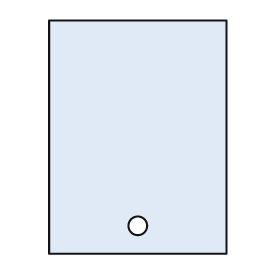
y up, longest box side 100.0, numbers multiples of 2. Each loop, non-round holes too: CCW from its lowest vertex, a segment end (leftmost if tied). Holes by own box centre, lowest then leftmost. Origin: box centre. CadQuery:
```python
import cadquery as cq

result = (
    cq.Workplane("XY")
    .moveTo(-38.0, -50.0)
    .lineTo(38.0, -50.0)
    .lineTo(38.0, 50.0)
    .lineTo(-38.0, 50.0)
    .close()
    .moveTo(0.0, -38.0)
    .circle(4.0)
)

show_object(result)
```